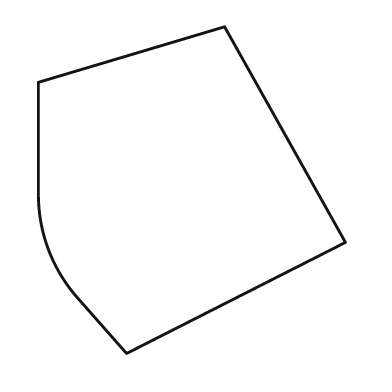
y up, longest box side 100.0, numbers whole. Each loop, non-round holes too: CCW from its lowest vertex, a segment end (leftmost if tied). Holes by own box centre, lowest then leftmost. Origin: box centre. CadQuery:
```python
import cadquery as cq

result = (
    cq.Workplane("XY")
    .moveTo(-20.0, -50.0)
    .lineTo(47.0, -16.0)
    .lineTo(10.0, 50.0)
    .lineTo(-47.0, 33.0)
    .lineTo(-47.0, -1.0)
    .threePointArc((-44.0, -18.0), (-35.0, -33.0))
    .close()
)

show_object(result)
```